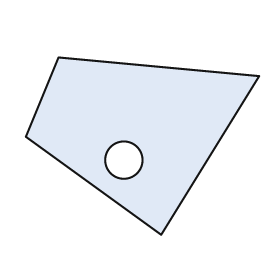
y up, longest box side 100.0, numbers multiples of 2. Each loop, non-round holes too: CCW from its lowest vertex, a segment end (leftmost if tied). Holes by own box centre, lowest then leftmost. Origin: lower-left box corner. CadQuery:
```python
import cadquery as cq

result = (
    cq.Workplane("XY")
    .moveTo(58.0, 0.0)
    .lineTo(100.0, 68.0)
    .lineTo(14.0, 76.0)
    .lineTo(0.0, 42.0)
    .close()
    .moveTo(42.0, 32.0)
    .circle(8.0)
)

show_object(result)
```